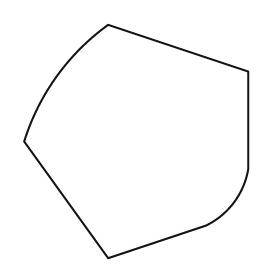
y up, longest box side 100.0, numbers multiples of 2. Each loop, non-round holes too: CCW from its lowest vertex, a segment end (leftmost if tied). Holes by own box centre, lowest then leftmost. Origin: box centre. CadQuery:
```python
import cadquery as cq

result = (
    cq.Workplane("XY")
    .moveTo(-12.0, -50.0)
    .lineTo(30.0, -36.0)
    .threePointArc((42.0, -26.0), (48.0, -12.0))
    .lineTo(48.0, 30.0)
    .lineTo(-12.0, 50.0)
    .threePointArc((-34.0, 28.0), (-48.0, 0.0))
    .close()
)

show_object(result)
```